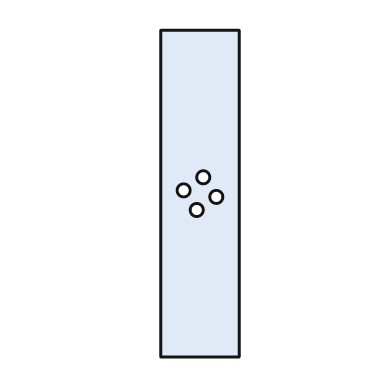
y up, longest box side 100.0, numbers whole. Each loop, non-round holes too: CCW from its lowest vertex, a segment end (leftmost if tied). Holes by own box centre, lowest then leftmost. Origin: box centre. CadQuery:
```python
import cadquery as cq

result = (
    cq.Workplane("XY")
    .moveTo(-12.0, -50.0)
    .lineTo(12.0, -50.0)
    .lineTo(12.0, 50.0)
    .lineTo(-12.0, 50.0)
    .close()
    .moveTo(-1.0, -5.0)
    .circle(2.0)
    .moveTo(5.0, -1.0)
    .circle(2.0)
    .moveTo(-5.0, 1.0)
    .circle(2.0)
    .moveTo(1.0, 5.0)
    .circle(2.0)
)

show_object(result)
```